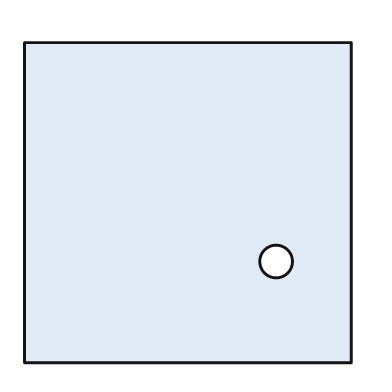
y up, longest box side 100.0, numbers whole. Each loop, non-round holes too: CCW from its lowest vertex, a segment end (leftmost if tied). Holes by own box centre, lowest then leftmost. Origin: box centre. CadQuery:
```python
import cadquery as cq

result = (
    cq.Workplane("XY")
    .moveTo(-50.0, -49.0)
    .lineTo(50.0, -49.0)
    .lineTo(50.0, 49.0)
    .lineTo(-50.0, 49.0)
    .close()
    .moveTo(27.0, -18.0)
    .circle(5.0)
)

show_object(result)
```